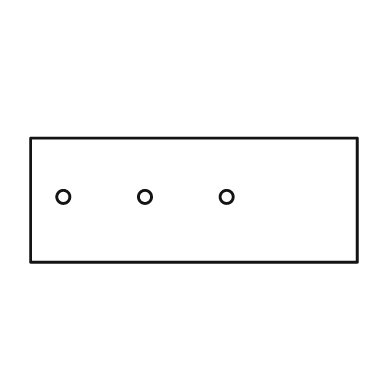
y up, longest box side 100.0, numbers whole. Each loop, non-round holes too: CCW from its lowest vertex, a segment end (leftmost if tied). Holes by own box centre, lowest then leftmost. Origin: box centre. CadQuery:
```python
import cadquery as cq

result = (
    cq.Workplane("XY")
    .moveTo(-50.0, -19.0)
    .lineTo(50.0, -19.0)
    .lineTo(50.0, 19.0)
    .lineTo(-50.0, 19.0)
    .close()
    .moveTo(-40.0, 1.0)
    .circle(2.0)
    .moveTo(-15.0, 1.0)
    .circle(2.0)
    .moveTo(10.0, 1.0)
    .circle(2.0)
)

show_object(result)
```